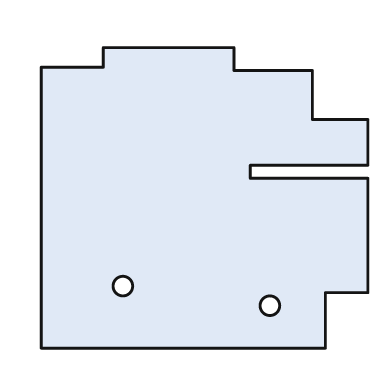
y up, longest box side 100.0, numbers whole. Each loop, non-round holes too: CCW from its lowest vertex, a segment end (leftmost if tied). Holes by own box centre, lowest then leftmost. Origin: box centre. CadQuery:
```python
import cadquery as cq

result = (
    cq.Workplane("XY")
    .moveTo(-50.0, -46.0)
    .lineTo(37.0, -46.0)
    .lineTo(37.0, -29.0)
    .lineTo(50.0, -29.0)
    .lineTo(50.0, 6.0)
    .lineTo(14.0, 6.0)
    .lineTo(14.0, 10.0)
    .lineTo(50.0, 10.0)
    .lineTo(50.0, 24.0)
    .lineTo(33.0, 24.0)
    .lineTo(33.0, 39.0)
    .lineTo(9.0, 39.0)
    .lineTo(9.0, 46.0)
    .lineTo(-31.0, 46.0)
    .lineTo(-31.0, 40.0)
    .lineTo(-50.0, 40.0)
    .close()
    .moveTo(20.0, -33.0)
    .circle(3.0)
    .moveTo(-25.0, -27.0)
    .circle(3.0)
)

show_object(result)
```